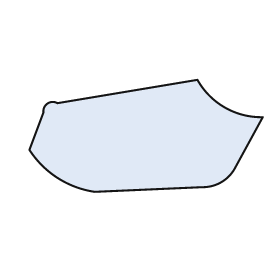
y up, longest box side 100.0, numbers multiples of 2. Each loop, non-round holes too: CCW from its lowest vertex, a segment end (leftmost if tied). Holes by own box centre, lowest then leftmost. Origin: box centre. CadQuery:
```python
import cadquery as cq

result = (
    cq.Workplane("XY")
    .moveTo(-22.0, -24.0)
    .lineTo(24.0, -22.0)
    .threePointArc((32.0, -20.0), (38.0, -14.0))
    .lineTo(50.0, 8.0)
    .threePointArc((34.0, 12.0), (22.0, 24.0))
    .lineTo(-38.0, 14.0)
    .threePointArc((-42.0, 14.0), (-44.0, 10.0))
    .lineTo(-50.0, -6.0)
    .threePointArc((-38.0, -18.0), (-22.0, -24.0))
    .close()
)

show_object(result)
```